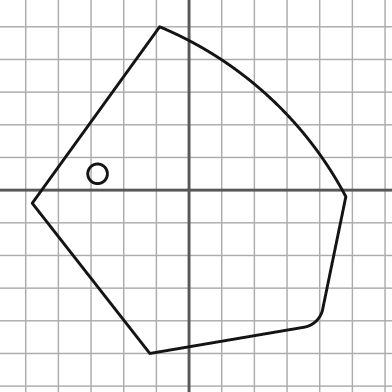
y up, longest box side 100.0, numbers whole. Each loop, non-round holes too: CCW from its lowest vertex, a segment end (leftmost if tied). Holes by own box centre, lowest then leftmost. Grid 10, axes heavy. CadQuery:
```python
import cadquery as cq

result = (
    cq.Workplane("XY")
    .moveTo(-12.0, -50.0)
    .lineTo(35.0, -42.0)
    .threePointArc((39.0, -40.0), (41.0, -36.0))
    .lineTo(48.0, -2.0)
    .threePointArc((24.0, 29.0), (-9.0, 50.0))
    .lineTo(-48.0, -4.0)
    .close()
    .moveTo(-28.0, 5.0)
    .circle(3.0)
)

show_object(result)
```